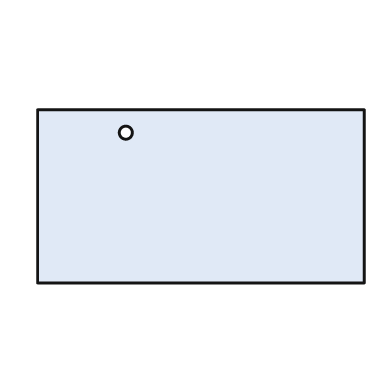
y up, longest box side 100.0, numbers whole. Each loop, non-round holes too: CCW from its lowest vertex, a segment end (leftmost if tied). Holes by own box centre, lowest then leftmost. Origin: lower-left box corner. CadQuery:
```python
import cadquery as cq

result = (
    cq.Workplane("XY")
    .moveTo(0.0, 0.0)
    .lineTo(100.0, 0.0)
    .lineTo(100.0, 53.0)
    .lineTo(0.0, 53.0)
    .close()
    .moveTo(27.0, 46.0)
    .circle(2.0)
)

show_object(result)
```